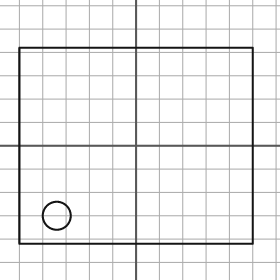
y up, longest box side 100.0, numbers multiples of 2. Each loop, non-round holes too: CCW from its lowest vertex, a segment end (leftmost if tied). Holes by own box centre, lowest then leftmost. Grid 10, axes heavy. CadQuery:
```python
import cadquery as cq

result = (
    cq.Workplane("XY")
    .moveTo(-50.0, -42.0)
    .lineTo(50.0, -42.0)
    .lineTo(50.0, 42.0)
    .lineTo(-50.0, 42.0)
    .close()
    .moveTo(-34.0, -30.0)
    .circle(6.0)
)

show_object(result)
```